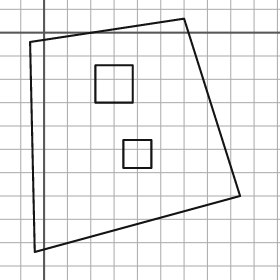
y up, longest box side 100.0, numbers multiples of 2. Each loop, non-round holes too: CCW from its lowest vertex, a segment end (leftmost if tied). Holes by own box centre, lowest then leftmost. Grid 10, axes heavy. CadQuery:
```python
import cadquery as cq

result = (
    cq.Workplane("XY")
    .moveTo(-4.0, -94.0)
    .lineTo(84.0, -70.0)
    .lineTo(60.0, 6.0)
    .lineTo(-6.0, -4.0)
    .close()
    .moveTo(34.0, -58.0)
    .lineTo(46.0, -58.0)
    .lineTo(46.0, -46.0)
    .lineTo(34.0, -46.0)
    .close()
    .moveTo(22.0, -30.0)
    .lineTo(38.0, -30.0)
    .lineTo(38.0, -14.0)
    .lineTo(22.0, -14.0)
    .close()
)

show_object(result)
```